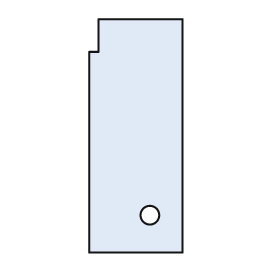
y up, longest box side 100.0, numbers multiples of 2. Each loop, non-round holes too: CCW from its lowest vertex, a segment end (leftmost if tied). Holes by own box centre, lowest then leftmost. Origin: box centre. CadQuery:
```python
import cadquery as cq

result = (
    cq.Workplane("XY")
    .moveTo(-20.0, -50.0)
    .lineTo(20.0, -50.0)
    .lineTo(20.0, 50.0)
    .lineTo(-16.0, 50.0)
    .lineTo(-16.0, 36.0)
    .lineTo(-20.0, 36.0)
    .close()
    .moveTo(6.0, -34.0)
    .circle(4.0)
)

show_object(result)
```